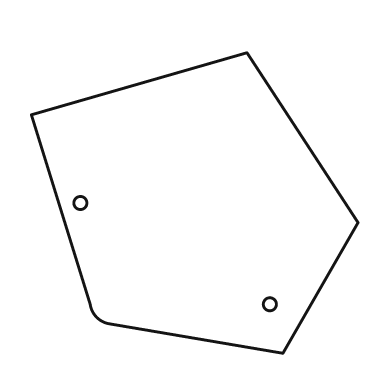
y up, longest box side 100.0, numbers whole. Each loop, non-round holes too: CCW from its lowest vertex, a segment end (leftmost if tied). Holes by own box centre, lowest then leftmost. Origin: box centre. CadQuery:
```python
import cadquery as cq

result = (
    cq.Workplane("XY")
    .moveTo(27.0, -46.0)
    .lineTo(50.0, -6.0)
    .lineTo(16.0, 46.0)
    .lineTo(-50.0, 27.0)
    .lineTo(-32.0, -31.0)
    .threePointArc((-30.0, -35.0), (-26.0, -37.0))
    .close()
    .moveTo(23.0, -31.0)
    .circle(2.0)
    .moveTo(-35.0, 0.0)
    .circle(2.0)
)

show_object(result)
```